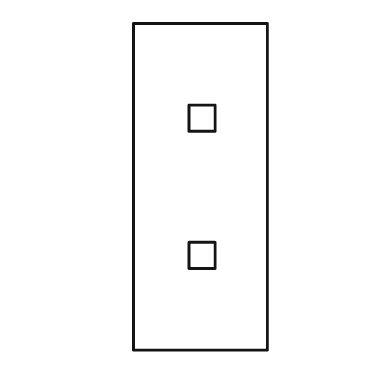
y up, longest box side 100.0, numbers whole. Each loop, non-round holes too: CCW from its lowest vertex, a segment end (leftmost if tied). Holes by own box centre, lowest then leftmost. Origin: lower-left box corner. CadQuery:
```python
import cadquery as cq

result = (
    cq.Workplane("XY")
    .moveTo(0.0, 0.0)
    .lineTo(41.0, 0.0)
    .lineTo(41.0, 100.0)
    .lineTo(0.0, 100.0)
    .close()
    .moveTo(17.0, 25.0)
    .lineTo(25.0, 25.0)
    .lineTo(25.0, 33.0)
    .lineTo(17.0, 33.0)
    .close()
    .moveTo(17.0, 67.0)
    .lineTo(25.0, 67.0)
    .lineTo(25.0, 75.0)
    .lineTo(17.0, 75.0)
    .close()
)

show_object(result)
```